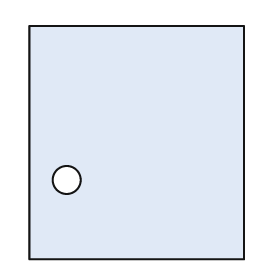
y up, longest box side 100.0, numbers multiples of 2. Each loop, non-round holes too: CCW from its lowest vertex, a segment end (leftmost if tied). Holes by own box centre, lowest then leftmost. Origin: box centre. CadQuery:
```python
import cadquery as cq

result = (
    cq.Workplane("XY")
    .moveTo(-46.0, -50.0)
    .lineTo(46.0, -50.0)
    .lineTo(46.0, 50.0)
    .lineTo(-46.0, 50.0)
    .close()
    .moveTo(-30.0, -16.0)
    .circle(6.0)
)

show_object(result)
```